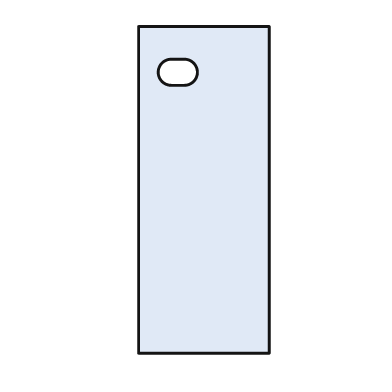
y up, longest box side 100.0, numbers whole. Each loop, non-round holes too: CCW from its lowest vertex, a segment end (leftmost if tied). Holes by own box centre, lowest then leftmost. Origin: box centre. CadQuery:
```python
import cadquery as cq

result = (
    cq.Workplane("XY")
    .moveTo(-20.0, -50.0)
    .lineTo(20.0, -50.0)
    .lineTo(20.0, 50.0)
    .lineTo(-20.0, 50.0)
    .close()
    .moveTo(-10.0, 32.0)
    .lineTo(-6.0, 32.0)
    .threePointArc((-2.0, 36.0), (-6.0, 40.0))
    .lineTo(-10.0, 40.0)
    .threePointArc((-14.0, 36.0), (-10.0, 32.0))
    .close()
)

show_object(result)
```